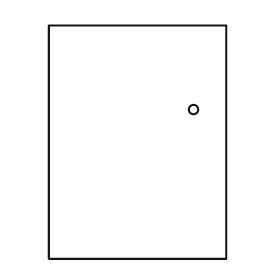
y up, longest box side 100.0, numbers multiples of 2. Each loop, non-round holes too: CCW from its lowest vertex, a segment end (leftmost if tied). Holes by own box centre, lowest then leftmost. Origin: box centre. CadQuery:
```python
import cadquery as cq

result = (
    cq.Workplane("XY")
    .moveTo(-38.0, -50.0)
    .lineTo(38.0, -50.0)
    .lineTo(38.0, 50.0)
    .lineTo(-38.0, 50.0)
    .close()
    .moveTo(24.0, 14.0)
    .circle(2.0)
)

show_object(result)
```